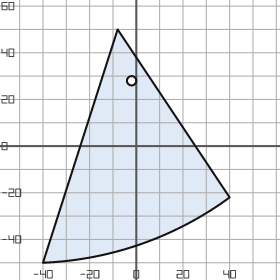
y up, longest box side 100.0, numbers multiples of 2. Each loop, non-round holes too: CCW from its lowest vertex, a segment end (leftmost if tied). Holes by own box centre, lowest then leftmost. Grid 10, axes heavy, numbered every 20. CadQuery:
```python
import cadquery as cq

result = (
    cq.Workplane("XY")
    .moveTo(-40.0, -50.0)
    .threePointArc((2.0, -42.0), (40.0, -22.0))
    .lineTo(-8.0, 50.0)
    .close()
    .moveTo(-2.0, 28.0)
    .circle(2.0)
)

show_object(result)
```